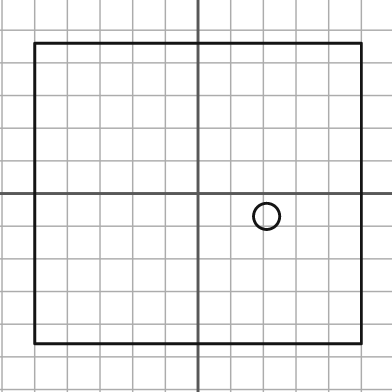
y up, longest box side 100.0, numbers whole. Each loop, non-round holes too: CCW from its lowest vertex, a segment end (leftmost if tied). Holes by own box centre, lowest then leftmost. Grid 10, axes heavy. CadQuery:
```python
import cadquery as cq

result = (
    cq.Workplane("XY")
    .moveTo(-50.0, -46.0)
    .lineTo(50.0, -46.0)
    .lineTo(50.0, 46.0)
    .lineTo(-50.0, 46.0)
    .close()
    .moveTo(21.0, -7.0)
    .circle(4.0)
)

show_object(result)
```